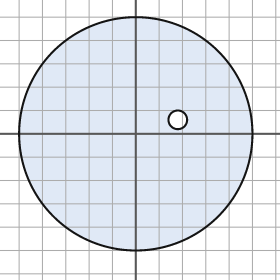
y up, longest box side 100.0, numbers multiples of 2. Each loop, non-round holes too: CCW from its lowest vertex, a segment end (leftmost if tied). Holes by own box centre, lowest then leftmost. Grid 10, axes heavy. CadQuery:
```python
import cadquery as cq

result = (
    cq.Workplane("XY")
    .moveTo(0.0, 0.0)
    .circle(50.0)
    .moveTo(18.0, 6.0)
    .circle(4.0)
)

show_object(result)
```